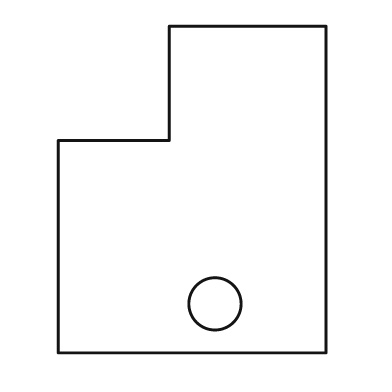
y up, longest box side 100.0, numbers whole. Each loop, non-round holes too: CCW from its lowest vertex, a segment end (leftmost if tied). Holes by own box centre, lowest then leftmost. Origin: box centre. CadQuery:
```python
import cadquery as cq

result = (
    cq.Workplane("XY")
    .moveTo(-41.0, -50.0)
    .lineTo(41.0, -50.0)
    .lineTo(41.0, 50.0)
    .lineTo(-7.0, 50.0)
    .lineTo(-7.0, 15.0)
    .lineTo(-41.0, 15.0)
    .close()
    .moveTo(7.0, -35.0)
    .circle(8.0)
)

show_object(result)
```